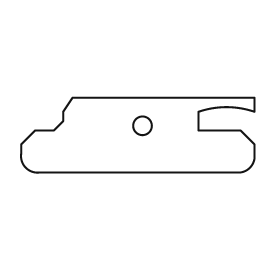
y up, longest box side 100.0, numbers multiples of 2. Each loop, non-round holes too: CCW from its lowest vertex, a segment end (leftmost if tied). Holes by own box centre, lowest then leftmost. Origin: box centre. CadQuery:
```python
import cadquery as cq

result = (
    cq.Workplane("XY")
    .moveTo(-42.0, -16.0)
    .lineTo(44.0, -16.0)
    .threePointArc((48.0, -14.0), (50.0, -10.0))
    .lineTo(50.0, -4.0)
    .lineTo(44.0, 2.0)
    .lineTo(26.0, 2.0)
    .lineTo(26.0, 10.0)
    .threePointArc((38.0, 12.0), (50.0, 10.0))
    .lineTo(50.0, 16.0)
    .lineTo(-28.0, 16.0)
    .lineTo(-32.0, 10.0)
    .lineTo(-32.0, 6.0)
    .lineTo(-36.0, 2.0)
    .lineTo(-44.0, 2.0)
    .lineTo(-50.0, -4.0)
    .lineTo(-50.0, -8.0)
    .threePointArc((-48.0, -14.0), (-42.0, -16.0))
    .close()
    .moveTo(2.0, 4.0)
    .circle(4.0)
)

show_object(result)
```